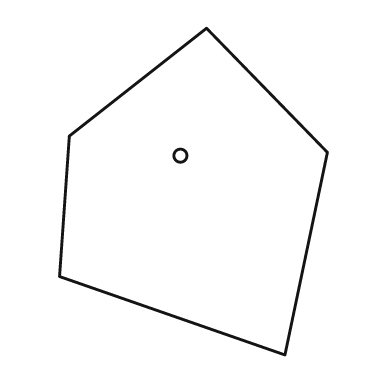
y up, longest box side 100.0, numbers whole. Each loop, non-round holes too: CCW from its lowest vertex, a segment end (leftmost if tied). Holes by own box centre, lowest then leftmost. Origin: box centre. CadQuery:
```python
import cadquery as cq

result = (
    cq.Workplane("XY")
    .moveTo(28.0, -50.0)
    .lineTo(41.0, 12.0)
    .lineTo(4.0, 50.0)
    .lineTo(-38.0, 17.0)
    .lineTo(-41.0, -26.0)
    .close()
    .moveTo(-4.0, 11.0)
    .circle(2.0)
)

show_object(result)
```